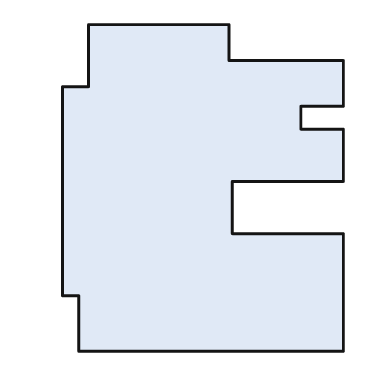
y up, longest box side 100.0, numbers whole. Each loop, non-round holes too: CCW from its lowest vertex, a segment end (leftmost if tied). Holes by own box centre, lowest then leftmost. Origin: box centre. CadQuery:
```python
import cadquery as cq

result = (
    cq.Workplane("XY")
    .moveTo(-38.0, -50.0)
    .lineTo(43.0, -50.0)
    .lineTo(43.0, -14.0)
    .lineTo(9.0, -14.0)
    .lineTo(9.0, 2.0)
    .lineTo(43.0, 2.0)
    .lineTo(43.0, 18.0)
    .lineTo(30.0, 18.0)
    .lineTo(30.0, 25.0)
    .lineTo(43.0, 25.0)
    .lineTo(43.0, 39.0)
    .lineTo(8.0, 39.0)
    .lineTo(8.0, 50.0)
    .lineTo(-35.0, 50.0)
    .lineTo(-35.0, 31.0)
    .lineTo(-43.0, 31.0)
    .lineTo(-43.0, -33.0)
    .lineTo(-38.0, -33.0)
    .close()
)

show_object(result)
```